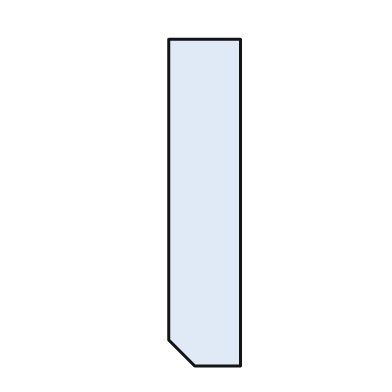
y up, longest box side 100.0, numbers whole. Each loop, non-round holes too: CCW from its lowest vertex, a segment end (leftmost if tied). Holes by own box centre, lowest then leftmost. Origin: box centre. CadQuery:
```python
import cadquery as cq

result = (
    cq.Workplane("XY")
    .moveTo(-3.0, -50.0)
    .lineTo(11.0, -50.0)
    .lineTo(11.0, 50.0)
    .lineTo(-11.0, 50.0)
    .lineTo(-11.0, -42.0)
    .close()
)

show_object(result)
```